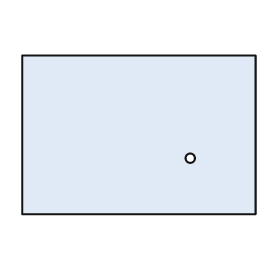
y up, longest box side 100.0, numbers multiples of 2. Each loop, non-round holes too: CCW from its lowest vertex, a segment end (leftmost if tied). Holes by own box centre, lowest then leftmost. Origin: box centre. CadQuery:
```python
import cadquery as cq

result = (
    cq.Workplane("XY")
    .moveTo(-50.0, -34.0)
    .lineTo(50.0, -34.0)
    .lineTo(50.0, 34.0)
    .lineTo(-50.0, 34.0)
    .close()
    .moveTo(22.0, -10.0)
    .circle(2.0)
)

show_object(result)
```